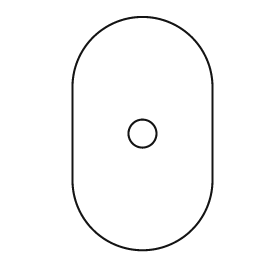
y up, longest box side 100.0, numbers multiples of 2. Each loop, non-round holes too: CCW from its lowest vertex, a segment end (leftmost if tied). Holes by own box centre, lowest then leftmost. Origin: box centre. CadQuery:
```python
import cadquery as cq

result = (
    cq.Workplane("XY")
    .moveTo(-30.0, -20.0)
    .threePointArc((0.0, -50.0), (30.0, -20.0))
    .lineTo(30.0, 20.0)
    .threePointArc((0.0, 50.0), (-30.0, 20.0))
    .close()
    .moveTo(0.0, 0.0)
    .circle(6.0)
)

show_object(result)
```